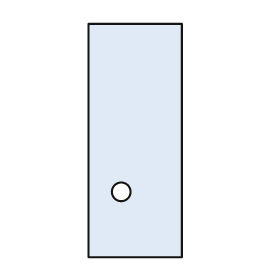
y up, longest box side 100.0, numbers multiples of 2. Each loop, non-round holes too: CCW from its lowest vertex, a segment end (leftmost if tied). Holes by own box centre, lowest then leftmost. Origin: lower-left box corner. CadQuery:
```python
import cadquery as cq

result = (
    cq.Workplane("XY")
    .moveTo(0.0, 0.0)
    .lineTo(40.0, 0.0)
    .lineTo(40.0, 100.0)
    .lineTo(0.0, 100.0)
    .close()
    .moveTo(14.0, 28.0)
    .circle(4.0)
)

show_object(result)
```